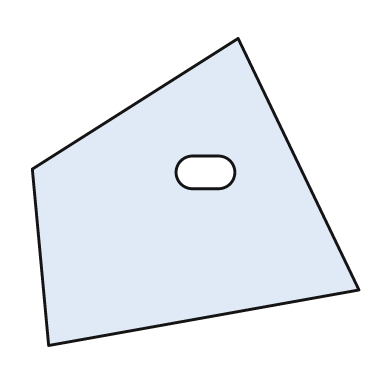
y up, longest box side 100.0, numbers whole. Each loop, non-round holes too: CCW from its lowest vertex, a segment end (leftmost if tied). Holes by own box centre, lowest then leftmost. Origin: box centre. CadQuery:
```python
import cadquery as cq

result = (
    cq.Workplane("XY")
    .moveTo(-45.0, -47.0)
    .lineTo(50.0, -30.0)
    .lineTo(13.0, 47.0)
    .lineTo(-50.0, 7.0)
    .close()
    .moveTo(-1.0, 1.0)
    .lineTo(7.0, 1.0)
    .threePointArc((12.0, 6.0), (7.0, 11.0))
    .lineTo(-1.0, 11.0)
    .threePointArc((-6.0, 6.0), (-1.0, 1.0))
    .close()
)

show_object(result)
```